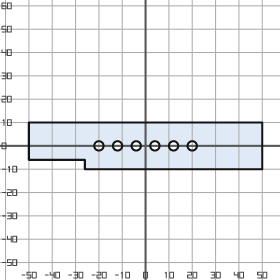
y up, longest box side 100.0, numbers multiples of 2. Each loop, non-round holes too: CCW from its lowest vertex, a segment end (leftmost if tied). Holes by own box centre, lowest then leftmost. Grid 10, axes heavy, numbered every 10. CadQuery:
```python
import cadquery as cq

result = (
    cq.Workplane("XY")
    .moveTo(-26.0, -10.0)
    .lineTo(50.0, -10.0)
    .lineTo(50.0, 10.0)
    .lineTo(-50.0, 10.0)
    .lineTo(-50.0, -6.0)
    .lineTo(-26.0, -6.0)
    .close()
    .moveTo(-20.0, 0.0)
    .circle(2.0)
    .moveTo(-12.0, 0.0)
    .circle(2.0)
    .moveTo(-4.0, 0.0)
    .circle(2.0)
    .moveTo(4.0, 0.0)
    .circle(2.0)
    .moveTo(12.0, 0.0)
    .circle(2.0)
    .moveTo(20.0, 0.0)
    .circle(2.0)
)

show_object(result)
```